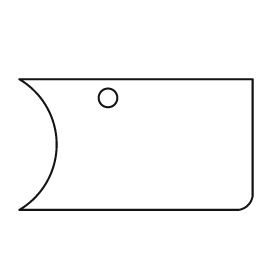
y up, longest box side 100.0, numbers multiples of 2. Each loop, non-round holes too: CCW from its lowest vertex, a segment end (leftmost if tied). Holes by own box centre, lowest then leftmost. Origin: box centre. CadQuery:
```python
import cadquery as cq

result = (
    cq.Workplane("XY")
    .moveTo(-50.0, -28.0)
    .lineTo(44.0, -28.0)
    .threePointArc((48.0, -26.0), (50.0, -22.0))
    .lineTo(50.0, 28.0)
    .lineTo(-50.0, 28.0)
    .threePointArc((-34.0, 0.0), (-50.0, -28.0))
    .close()
    .moveTo(-12.0, 20.0)
    .circle(4.0)
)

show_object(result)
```